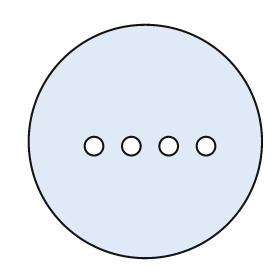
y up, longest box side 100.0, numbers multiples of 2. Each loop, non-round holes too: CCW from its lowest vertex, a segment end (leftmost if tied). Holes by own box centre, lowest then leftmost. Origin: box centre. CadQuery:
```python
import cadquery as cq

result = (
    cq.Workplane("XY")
    .moveTo(0.0, 0.0)
    .circle(50.0)
    .moveTo(-22.0, -2.0)
    .circle(4.0)
    .moveTo(-6.0, -2.0)
    .circle(4.0)
    .moveTo(10.0, -2.0)
    .circle(4.0)
    .moveTo(26.0, -2.0)
    .circle(4.0)
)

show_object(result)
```